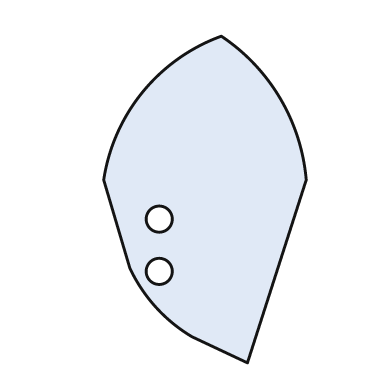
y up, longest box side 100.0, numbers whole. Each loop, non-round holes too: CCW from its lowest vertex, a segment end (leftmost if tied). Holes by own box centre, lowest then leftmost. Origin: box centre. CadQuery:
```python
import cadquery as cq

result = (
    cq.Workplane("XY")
    .moveTo(13.0, -50.0)
    .lineTo(31.0, 6.0)
    .threePointArc((23.0, 31.0), (5.0, 50.0))
    .threePointArc((-19.0, 33.0), (-31.0, 6.0))
    .lineTo(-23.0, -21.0)
    .threePointArc((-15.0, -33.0), (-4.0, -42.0))
    .close()
    .moveTo(-14.0, -22.0)
    .circle(4.0)
    .moveTo(-14.0, -6.0)
    .circle(4.0)
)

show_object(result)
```